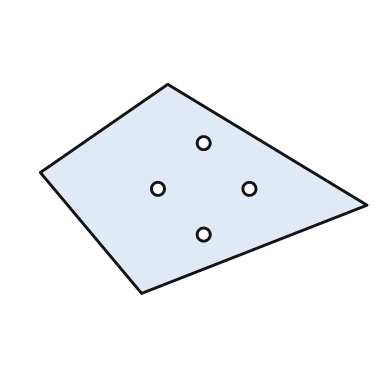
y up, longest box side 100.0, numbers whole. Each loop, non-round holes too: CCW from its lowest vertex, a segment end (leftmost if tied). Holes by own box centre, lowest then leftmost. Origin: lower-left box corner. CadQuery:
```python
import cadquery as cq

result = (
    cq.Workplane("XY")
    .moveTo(31.0, 0.0)
    .lineTo(100.0, 27.0)
    .lineTo(39.0, 64.0)
    .lineTo(0.0, 37.0)
    .close()
    .moveTo(50.0, 18.0)
    .circle(2.0)
    .moveTo(36.0, 32.0)
    .circle(2.0)
    .moveTo(64.0, 32.0)
    .circle(2.0)
    .moveTo(50.0, 46.0)
    .circle(2.0)
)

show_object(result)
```